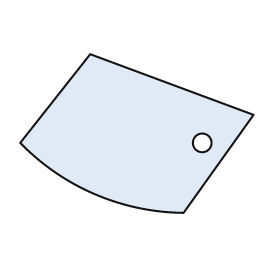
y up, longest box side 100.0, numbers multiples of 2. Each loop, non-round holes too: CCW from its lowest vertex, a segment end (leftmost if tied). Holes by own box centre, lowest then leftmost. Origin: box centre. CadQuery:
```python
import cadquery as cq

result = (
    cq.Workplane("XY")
    .moveTo(20.0, -34.0)
    .lineTo(50.0, 8.0)
    .lineTo(-20.0, 34.0)
    .lineTo(-50.0, -4.0)
    .threePointArc((-18.0, -26.0), (20.0, -34.0))
    .close()
    .moveTo(28.0, -4.0)
    .circle(4.0)
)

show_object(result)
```